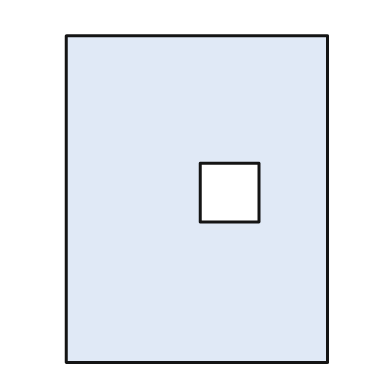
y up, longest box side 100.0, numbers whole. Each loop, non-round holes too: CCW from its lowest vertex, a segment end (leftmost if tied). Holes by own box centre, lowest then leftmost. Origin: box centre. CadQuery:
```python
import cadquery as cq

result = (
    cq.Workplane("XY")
    .moveTo(-40.0, -50.0)
    .lineTo(40.0, -50.0)
    .lineTo(40.0, 50.0)
    .lineTo(-40.0, 50.0)
    .close()
    .moveTo(1.0, -7.0)
    .lineTo(19.0, -7.0)
    .lineTo(19.0, 11.0)
    .lineTo(1.0, 11.0)
    .close()
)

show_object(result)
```